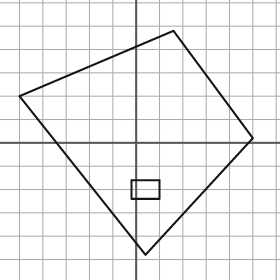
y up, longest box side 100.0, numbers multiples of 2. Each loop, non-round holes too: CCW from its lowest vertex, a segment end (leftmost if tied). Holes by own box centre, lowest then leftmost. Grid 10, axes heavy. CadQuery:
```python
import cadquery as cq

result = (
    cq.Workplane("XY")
    .moveTo(4.0, -48.0)
    .lineTo(50.0, 2.0)
    .lineTo(16.0, 48.0)
    .lineTo(-50.0, 20.0)
    .close()
    .moveTo(-2.0, -24.0)
    .lineTo(10.0, -24.0)
    .lineTo(10.0, -16.0)
    .lineTo(-2.0, -16.0)
    .close()
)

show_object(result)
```